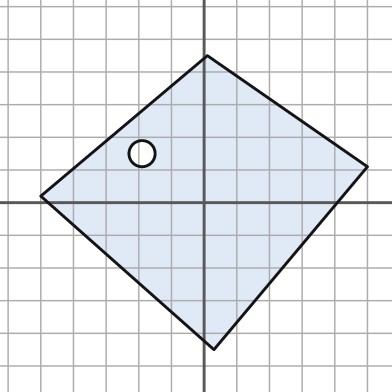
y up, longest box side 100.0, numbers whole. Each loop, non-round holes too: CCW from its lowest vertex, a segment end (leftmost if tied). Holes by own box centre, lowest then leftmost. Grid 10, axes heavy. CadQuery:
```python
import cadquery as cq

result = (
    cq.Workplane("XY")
    .moveTo(3.0, -45.0)
    .lineTo(50.0, 11.0)
    .lineTo(1.0, 45.0)
    .lineTo(-50.0, 2.0)
    .close()
    .moveTo(-19.0, 15.0)
    .circle(4.0)
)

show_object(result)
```